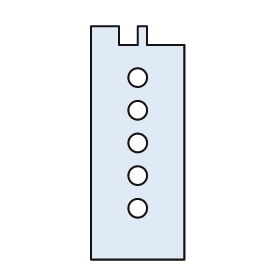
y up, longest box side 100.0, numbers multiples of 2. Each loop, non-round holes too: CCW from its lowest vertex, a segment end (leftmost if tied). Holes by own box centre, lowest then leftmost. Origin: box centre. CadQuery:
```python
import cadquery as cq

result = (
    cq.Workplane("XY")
    .moveTo(-20.0, -50.0)
    .lineTo(20.0, -50.0)
    .lineTo(20.0, 42.0)
    .lineTo(4.0, 42.0)
    .lineTo(4.0, 50.0)
    .lineTo(0.0, 50.0)
    .lineTo(0.0, 42.0)
    .lineTo(-8.0, 42.0)
    .lineTo(-8.0, 50.0)
    .lineTo(-20.0, 50.0)
    .close()
    .moveTo(0.0, -28.0)
    .circle(4.0)
    .moveTo(0.0, -14.0)
    .circle(4.0)
    .moveTo(0.0, 0.0)
    .circle(4.0)
    .moveTo(0.0, 14.0)
    .circle(4.0)
    .moveTo(0.0, 28.0)
    .circle(4.0)
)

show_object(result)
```